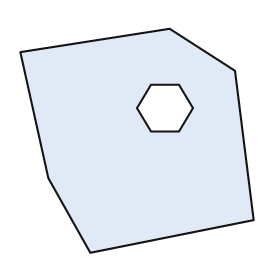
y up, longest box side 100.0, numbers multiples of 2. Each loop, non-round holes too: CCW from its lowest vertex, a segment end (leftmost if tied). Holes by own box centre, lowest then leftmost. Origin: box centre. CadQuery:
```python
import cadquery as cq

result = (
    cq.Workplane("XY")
    .moveTo(-20.0, -48.0)
    .lineTo(50.0, -34.0)
    .lineTo(42.0, 30.0)
    .lineTo(14.0, 48.0)
    .lineTo(-50.0, 38.0)
    .lineTo(-38.0, -16.0)
    .close()
    .moveTo(6.0, 4.0)
    .lineTo(18.0, 4.0)
    .lineTo(24.0, 14.0)
    .lineTo(18.0, 24.0)
    .lineTo(6.0, 24.0)
    .lineTo(0.0, 14.0)
    .close()
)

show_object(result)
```